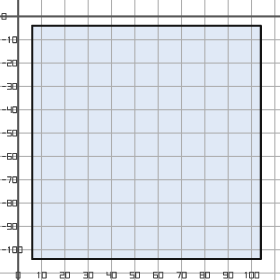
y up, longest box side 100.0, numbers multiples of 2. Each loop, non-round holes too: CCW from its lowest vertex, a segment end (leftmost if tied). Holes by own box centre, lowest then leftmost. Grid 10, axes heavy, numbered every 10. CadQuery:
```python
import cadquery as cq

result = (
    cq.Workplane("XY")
    .moveTo(6.0, -104.0)
    .lineTo(104.0, -104.0)
    .lineTo(104.0, -4.0)
    .lineTo(6.0, -4.0)
    .close()
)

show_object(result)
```